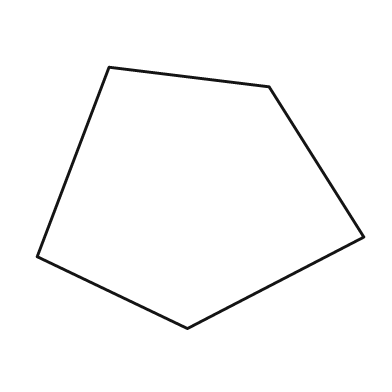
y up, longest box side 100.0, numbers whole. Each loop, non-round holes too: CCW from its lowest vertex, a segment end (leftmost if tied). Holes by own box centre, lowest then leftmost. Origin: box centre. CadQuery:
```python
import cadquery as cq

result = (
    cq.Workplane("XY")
    .moveTo(-4.0, -40.0)
    .lineTo(50.0, -12.0)
    .lineTo(21.0, 34.0)
    .lineTo(-28.0, 40.0)
    .lineTo(-50.0, -18.0)
    .close()
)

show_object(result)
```